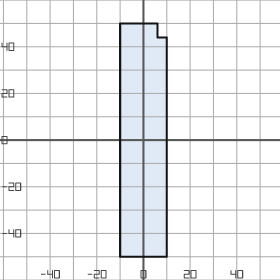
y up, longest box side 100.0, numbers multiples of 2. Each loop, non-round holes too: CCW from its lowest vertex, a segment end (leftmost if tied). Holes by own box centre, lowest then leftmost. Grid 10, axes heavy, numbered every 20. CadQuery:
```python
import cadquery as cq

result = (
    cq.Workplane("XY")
    .moveTo(-10.0, -50.0)
    .lineTo(10.0, -50.0)
    .lineTo(10.0, 44.0)
    .lineTo(6.0, 44.0)
    .lineTo(6.0, 50.0)
    .lineTo(-10.0, 50.0)
    .close()
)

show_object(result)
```